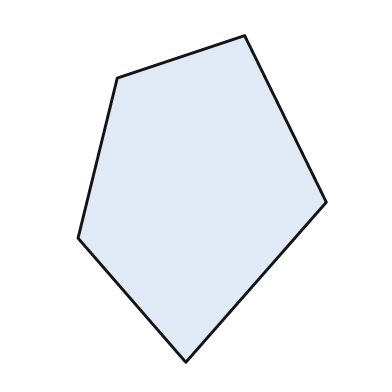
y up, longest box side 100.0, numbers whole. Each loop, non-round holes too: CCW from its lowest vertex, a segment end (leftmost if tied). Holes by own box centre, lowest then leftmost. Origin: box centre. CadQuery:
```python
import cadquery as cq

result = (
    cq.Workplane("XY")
    .moveTo(-5.0, -50.0)
    .lineTo(38.0, -1.0)
    .lineTo(13.0, 50.0)
    .lineTo(-26.0, 37.0)
    .lineTo(-38.0, -12.0)
    .close()
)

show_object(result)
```